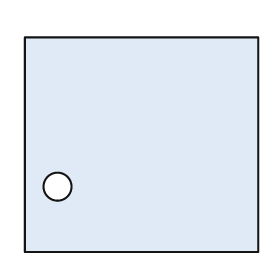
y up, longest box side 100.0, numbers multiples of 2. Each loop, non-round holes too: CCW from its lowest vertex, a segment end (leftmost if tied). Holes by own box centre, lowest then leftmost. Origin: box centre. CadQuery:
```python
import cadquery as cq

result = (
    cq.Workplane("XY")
    .moveTo(-50.0, -46.0)
    .lineTo(50.0, -46.0)
    .lineTo(50.0, 46.0)
    .lineTo(-50.0, 46.0)
    .close()
    .moveTo(-36.0, -18.0)
    .circle(6.0)
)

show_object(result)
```